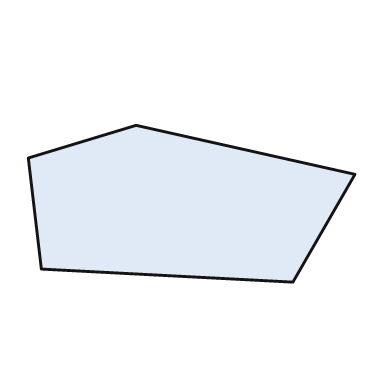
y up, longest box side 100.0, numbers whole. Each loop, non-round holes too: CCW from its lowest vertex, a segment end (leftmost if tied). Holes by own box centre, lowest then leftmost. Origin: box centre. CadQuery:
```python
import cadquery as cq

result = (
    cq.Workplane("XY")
    .moveTo(31.0, -24.0)
    .lineTo(50.0, 9.0)
    .lineTo(-17.0, 24.0)
    .lineTo(-50.0, 14.0)
    .lineTo(-46.0, -20.0)
    .close()
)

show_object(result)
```